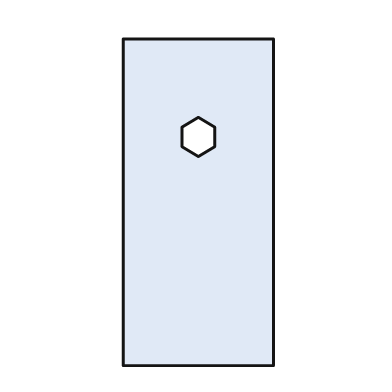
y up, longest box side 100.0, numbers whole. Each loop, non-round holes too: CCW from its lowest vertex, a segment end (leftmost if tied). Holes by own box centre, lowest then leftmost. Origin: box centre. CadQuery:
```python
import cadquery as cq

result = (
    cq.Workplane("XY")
    .moveTo(-23.0, -50.0)
    .lineTo(23.0, -50.0)
    .lineTo(23.0, 50.0)
    .lineTo(-23.0, 50.0)
    .close()
    .moveTo(0.0, 14.0)
    .lineTo(5.0, 17.0)
    .lineTo(5.0, 23.0)
    .lineTo(0.0, 26.0)
    .lineTo(-5.0, 23.0)
    .lineTo(-5.0, 17.0)
    .close()
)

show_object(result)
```